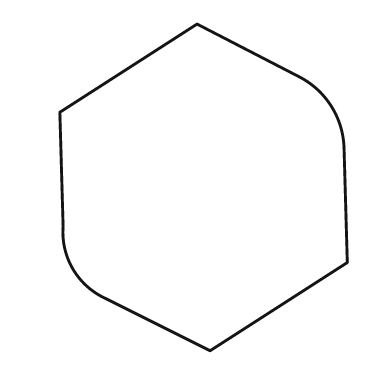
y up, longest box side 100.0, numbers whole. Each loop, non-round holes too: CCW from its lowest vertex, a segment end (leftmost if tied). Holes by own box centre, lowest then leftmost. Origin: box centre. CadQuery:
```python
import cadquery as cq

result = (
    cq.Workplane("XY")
    .moveTo(2.0, -50.0)
    .lineTo(44.0, -23.0)
    .lineTo(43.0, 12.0)
    .threePointArc((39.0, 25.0), (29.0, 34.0))
    .lineTo(-2.0, 50.0)
    .lineTo(-44.0, 23.0)
    .lineTo(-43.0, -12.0)
    .threePointArc((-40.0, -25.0), (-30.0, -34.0))
    .close()
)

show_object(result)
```